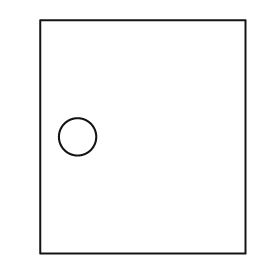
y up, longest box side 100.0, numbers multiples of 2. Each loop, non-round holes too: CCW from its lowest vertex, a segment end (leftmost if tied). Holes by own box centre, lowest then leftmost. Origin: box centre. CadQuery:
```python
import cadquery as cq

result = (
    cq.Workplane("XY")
    .moveTo(-44.0, -50.0)
    .lineTo(44.0, -50.0)
    .lineTo(44.0, 50.0)
    .lineTo(-44.0, 50.0)
    .close()
    .moveTo(-28.0, 0.0)
    .circle(8.0)
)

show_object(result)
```